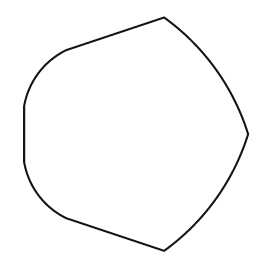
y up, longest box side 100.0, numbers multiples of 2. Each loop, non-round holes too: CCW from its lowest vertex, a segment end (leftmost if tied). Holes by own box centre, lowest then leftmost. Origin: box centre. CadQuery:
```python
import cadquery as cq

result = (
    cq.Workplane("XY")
    .moveTo(12.0, -50.0)
    .threePointArc((34.0, -28.0), (48.0, 0.0))
    .threePointArc((34.0, 28.0), (12.0, 50.0))
    .lineTo(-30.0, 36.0)
    .threePointArc((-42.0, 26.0), (-48.0, 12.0))
    .lineTo(-48.0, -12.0)
    .threePointArc((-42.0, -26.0), (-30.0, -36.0))
    .close()
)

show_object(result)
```